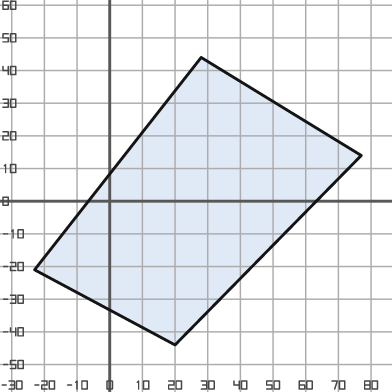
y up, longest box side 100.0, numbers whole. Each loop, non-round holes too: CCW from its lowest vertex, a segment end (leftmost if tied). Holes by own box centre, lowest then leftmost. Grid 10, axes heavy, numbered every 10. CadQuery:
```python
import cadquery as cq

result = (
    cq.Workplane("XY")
    .moveTo(20.0, -44.0)
    .lineTo(77.0, 14.0)
    .lineTo(28.0, 44.0)
    .lineTo(-23.0, -21.0)
    .close()
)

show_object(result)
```